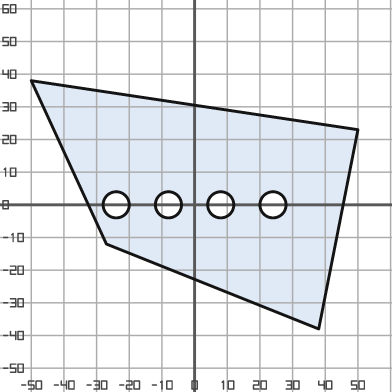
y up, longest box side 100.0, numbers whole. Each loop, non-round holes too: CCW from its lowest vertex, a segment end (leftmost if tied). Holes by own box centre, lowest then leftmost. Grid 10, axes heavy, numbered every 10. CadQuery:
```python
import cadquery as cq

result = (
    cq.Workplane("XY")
    .moveTo(38.0, -38.0)
    .lineTo(50.0, 23.0)
    .lineTo(-50.0, 38.0)
    .lineTo(-27.0, -12.0)
    .close()
    .moveTo(-24.0, 0.0)
    .circle(4.0)
    .moveTo(-8.0, 0.0)
    .circle(4.0)
    .moveTo(8.0, 0.0)
    .circle(4.0)
    .moveTo(24.0, 0.0)
    .circle(4.0)
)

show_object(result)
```